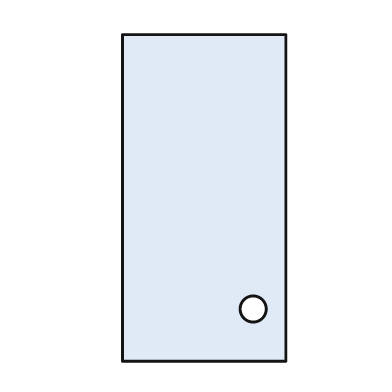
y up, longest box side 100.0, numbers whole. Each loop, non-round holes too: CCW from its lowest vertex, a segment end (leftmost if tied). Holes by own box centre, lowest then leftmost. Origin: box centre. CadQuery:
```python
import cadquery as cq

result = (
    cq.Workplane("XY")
    .moveTo(-25.0, -50.0)
    .lineTo(25.0, -50.0)
    .lineTo(25.0, 50.0)
    .lineTo(-25.0, 50.0)
    .close()
    .moveTo(15.0, -34.0)
    .circle(4.0)
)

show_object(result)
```